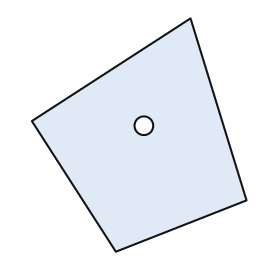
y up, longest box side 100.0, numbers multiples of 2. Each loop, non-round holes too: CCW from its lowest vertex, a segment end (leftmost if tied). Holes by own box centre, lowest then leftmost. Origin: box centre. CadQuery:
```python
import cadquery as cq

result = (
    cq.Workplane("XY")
    .moveTo(-10.0, -50.0)
    .lineTo(46.0, -28.0)
    .lineTo(22.0, 50.0)
    .lineTo(-46.0, 6.0)
    .close()
    .moveTo(2.0, 4.0)
    .circle(4.0)
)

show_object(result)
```